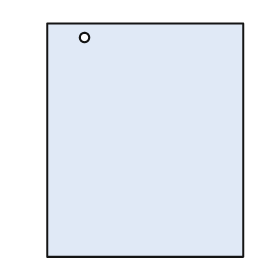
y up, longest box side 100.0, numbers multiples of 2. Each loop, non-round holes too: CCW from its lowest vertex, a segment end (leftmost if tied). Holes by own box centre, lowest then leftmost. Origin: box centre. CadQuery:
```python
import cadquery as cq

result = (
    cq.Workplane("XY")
    .moveTo(-42.0, -50.0)
    .lineTo(42.0, -50.0)
    .lineTo(42.0, 50.0)
    .lineTo(-42.0, 50.0)
    .close()
    .moveTo(-26.0, 44.0)
    .circle(2.0)
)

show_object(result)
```